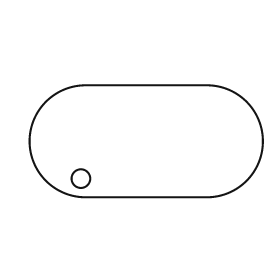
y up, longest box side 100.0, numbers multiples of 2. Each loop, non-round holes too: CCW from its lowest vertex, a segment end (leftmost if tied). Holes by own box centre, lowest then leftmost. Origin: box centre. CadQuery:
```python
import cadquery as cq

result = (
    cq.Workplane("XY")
    .moveTo(-26.0, -24.0)
    .lineTo(26.0, -24.0)
    .threePointArc((50.0, 0.0), (26.0, 24.0))
    .lineTo(-26.0, 24.0)
    .threePointArc((-50.0, 0.0), (-26.0, -24.0))
    .close()
    .moveTo(-28.0, -16.0)
    .circle(4.0)
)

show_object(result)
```